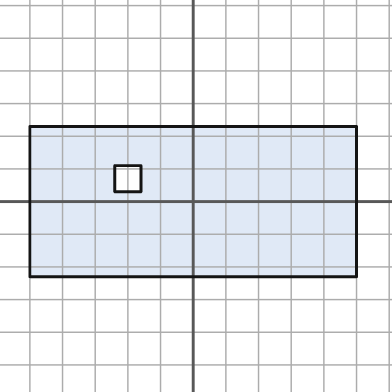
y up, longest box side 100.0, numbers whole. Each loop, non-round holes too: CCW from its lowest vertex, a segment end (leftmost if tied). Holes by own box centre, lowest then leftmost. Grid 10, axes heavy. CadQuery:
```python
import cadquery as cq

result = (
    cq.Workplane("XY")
    .moveTo(-50.0, -23.0)
    .lineTo(50.0, -23.0)
    .lineTo(50.0, 23.0)
    .lineTo(-50.0, 23.0)
    .close()
    .moveTo(-24.0, 3.0)
    .lineTo(-16.0, 3.0)
    .lineTo(-16.0, 11.0)
    .lineTo(-24.0, 11.0)
    .close()
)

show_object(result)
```